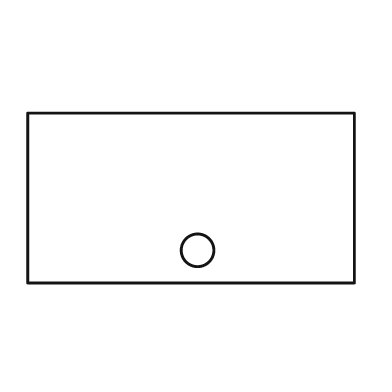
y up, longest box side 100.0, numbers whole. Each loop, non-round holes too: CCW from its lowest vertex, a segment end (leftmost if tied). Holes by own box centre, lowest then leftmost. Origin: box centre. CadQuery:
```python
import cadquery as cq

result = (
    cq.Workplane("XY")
    .moveTo(-50.0, -26.0)
    .lineTo(50.0, -26.0)
    .lineTo(50.0, 26.0)
    .lineTo(-50.0, 26.0)
    .close()
    .moveTo(2.0, -16.0)
    .circle(5.0)
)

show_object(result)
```